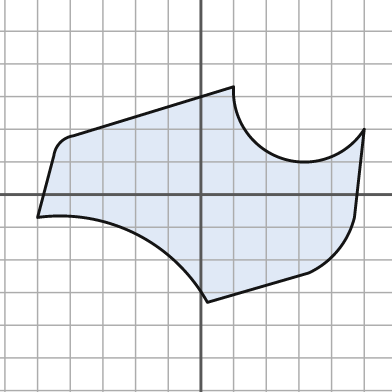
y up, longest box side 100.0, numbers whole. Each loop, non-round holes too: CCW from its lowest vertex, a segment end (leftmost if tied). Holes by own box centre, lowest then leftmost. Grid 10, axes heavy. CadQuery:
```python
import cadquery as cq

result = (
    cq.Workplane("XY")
    .moveTo(2.0, -33.0)
    .lineTo(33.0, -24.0)
    .threePointArc((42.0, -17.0), (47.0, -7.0))
    .lineTo(50.0, 20.0)
    .threePointArc((25.0, 11.0), (10.0, 33.0))
    .lineTo(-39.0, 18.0)
    .threePointArc((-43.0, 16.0), (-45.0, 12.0))
    .lineTo(-50.0, -7.0)
    .threePointArc((-20.0, -12.0), (2.0, -33.0))
    .close()
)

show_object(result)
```